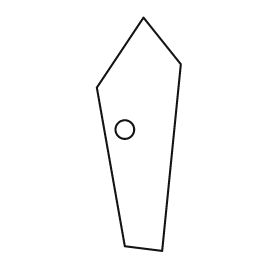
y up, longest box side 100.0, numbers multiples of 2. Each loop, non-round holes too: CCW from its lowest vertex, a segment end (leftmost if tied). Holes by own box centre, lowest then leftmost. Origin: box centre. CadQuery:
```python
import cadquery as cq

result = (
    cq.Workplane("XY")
    .moveTo(10.0, -50.0)
    .lineTo(18.0, 30.0)
    .lineTo(2.0, 50.0)
    .lineTo(-18.0, 20.0)
    .lineTo(-6.0, -48.0)
    .close()
    .moveTo(-6.0, 2.0)
    .circle(4.0)
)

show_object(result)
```